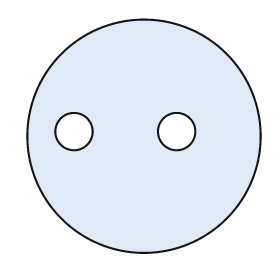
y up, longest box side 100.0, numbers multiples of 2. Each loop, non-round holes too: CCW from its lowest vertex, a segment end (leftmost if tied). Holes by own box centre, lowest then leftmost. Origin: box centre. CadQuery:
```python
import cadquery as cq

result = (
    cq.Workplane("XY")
    .moveTo(0.0, 0.0)
    .circle(50.0)
    .moveTo(-30.0, 2.0)
    .circle(8.0)
    .moveTo(14.0, 2.0)
    .circle(8.0)
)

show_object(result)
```